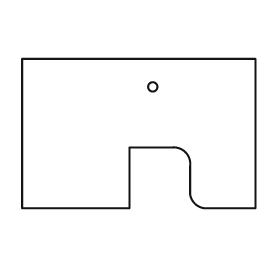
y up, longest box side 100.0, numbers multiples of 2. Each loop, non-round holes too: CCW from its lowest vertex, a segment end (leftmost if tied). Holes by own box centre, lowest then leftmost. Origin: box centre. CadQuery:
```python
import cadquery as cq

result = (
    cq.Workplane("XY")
    .moveTo(-50.0, -32.0)
    .lineTo(-4.0, -32.0)
    .lineTo(-4.0, -6.0)
    .lineTo(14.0, -6.0)
    .threePointArc((20.0, -8.0), (22.0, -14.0))
    .lineTo(22.0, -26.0)
    .threePointArc((24.0, -30.0), (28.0, -32.0))
    .lineTo(50.0, -32.0)
    .lineTo(50.0, 32.0)
    .lineTo(-50.0, 32.0)
    .close()
    .moveTo(6.0, 20.0)
    .circle(2.0)
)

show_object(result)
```